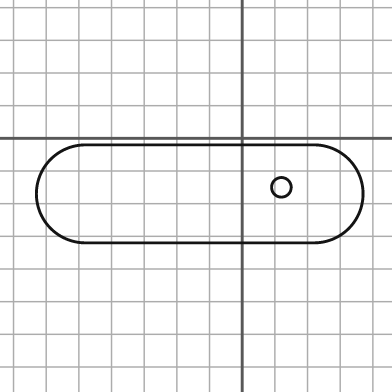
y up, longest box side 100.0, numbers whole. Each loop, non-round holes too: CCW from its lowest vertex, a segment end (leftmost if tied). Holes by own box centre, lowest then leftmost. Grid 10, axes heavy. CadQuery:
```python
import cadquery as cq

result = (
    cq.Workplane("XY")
    .moveTo(-48.0, -32.0)
    .lineTo(22.0, -32.0)
    .threePointArc((37.0, -17.0), (22.0, -2.0))
    .lineTo(-48.0, -2.0)
    .threePointArc((-63.0, -17.0), (-48.0, -32.0))
    .close()
    .moveTo(12.0, -15.0)
    .circle(3.0)
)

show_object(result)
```